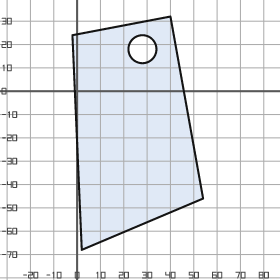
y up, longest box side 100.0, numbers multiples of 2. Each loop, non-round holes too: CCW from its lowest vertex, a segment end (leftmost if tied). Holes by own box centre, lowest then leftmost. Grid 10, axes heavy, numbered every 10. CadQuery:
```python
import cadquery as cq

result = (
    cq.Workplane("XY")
    .moveTo(2.0, -68.0)
    .lineTo(54.0, -46.0)
    .lineTo(40.0, 32.0)
    .lineTo(-2.0, 24.0)
    .close()
    .moveTo(28.0, 18.0)
    .circle(6.0)
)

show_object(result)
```